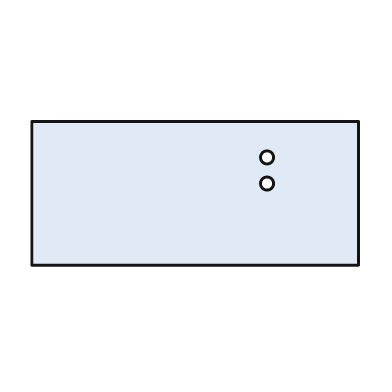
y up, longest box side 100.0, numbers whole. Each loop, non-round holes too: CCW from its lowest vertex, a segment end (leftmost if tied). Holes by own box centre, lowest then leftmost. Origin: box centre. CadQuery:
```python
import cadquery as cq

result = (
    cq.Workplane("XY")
    .moveTo(-50.0, -22.0)
    .lineTo(50.0, -22.0)
    .lineTo(50.0, 22.0)
    .lineTo(-50.0, 22.0)
    .close()
    .moveTo(22.0, 3.0)
    .circle(2.0)
    .moveTo(22.0, 11.0)
    .circle(2.0)
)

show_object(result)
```